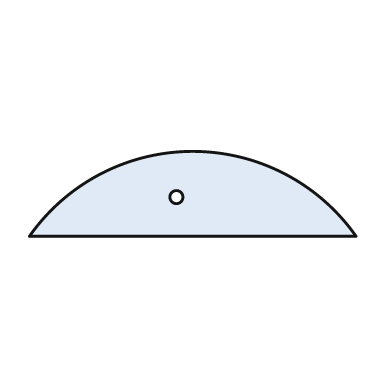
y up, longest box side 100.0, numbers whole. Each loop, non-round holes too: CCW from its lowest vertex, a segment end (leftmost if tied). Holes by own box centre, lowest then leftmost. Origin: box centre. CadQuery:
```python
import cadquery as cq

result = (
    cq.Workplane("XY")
    .moveTo(-50.0, -13.0)
    .lineTo(50.0, -13.0)
    .threePointArc((0.0, 13.0), (-50.0, -13.0))
    .close()
    .moveTo(-5.0, -1.0)
    .circle(2.0)
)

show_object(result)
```